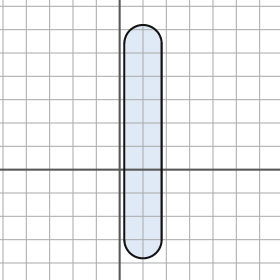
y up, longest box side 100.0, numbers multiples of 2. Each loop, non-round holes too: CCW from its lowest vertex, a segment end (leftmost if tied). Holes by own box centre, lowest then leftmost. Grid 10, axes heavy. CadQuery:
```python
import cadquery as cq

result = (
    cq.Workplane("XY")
    .moveTo(2.0, -30.0)
    .threePointArc((10.0, -38.0), (18.0, -30.0))
    .lineTo(18.0, 54.0)
    .threePointArc((10.0, 62.0), (2.0, 54.0))
    .close()
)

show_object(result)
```